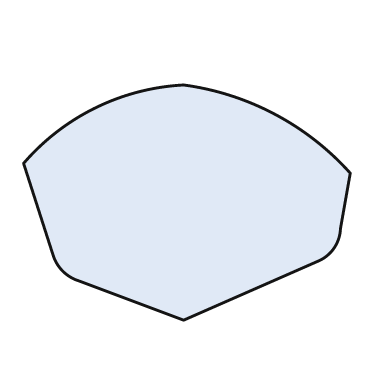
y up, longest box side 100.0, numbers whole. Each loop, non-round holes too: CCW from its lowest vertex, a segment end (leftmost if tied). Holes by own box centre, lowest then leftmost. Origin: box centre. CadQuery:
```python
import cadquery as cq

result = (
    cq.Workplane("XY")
    .moveTo(-1.0, -36.0)
    .lineTo(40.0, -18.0)
    .threePointArc((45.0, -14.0), (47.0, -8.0))
    .lineTo(50.0, 9.0)
    .threePointArc((27.0, 27.0), (-1.0, 36.0))
    .threePointArc((-28.0, 29.0), (-50.0, 12.0))
    .lineTo(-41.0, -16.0)
    .threePointArc((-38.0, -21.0), (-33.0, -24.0))
    .close()
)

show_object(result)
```